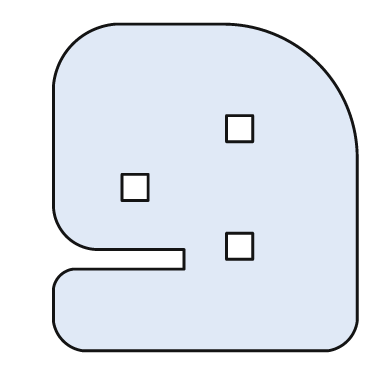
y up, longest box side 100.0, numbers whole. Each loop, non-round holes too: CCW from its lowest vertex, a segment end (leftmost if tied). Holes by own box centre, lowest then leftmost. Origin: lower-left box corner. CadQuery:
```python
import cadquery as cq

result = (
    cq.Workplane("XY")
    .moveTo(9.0, 0.0)
    .lineTo(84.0, 0.0)
    .threePointArc((90.0, 3.0), (93.0, 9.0))
    .lineTo(93.0, 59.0)
    .threePointArc((81.0, 88.0), (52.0, 100.0))
    .lineTo(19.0, 100.0)
    .threePointArc((6.0, 94.0), (0.0, 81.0))
    .lineTo(0.0, 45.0)
    .threePointArc((4.0, 35.0), (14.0, 31.0))
    .lineTo(40.0, 31.0)
    .lineTo(40.0, 25.0)
    .lineTo(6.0, 25.0)
    .threePointArc((2.0, 23.0), (0.0, 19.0))
    .lineTo(0.0, 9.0)
    .threePointArc((3.0, 3.0), (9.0, 0.0))
    .close()
    .moveTo(53.0, 28.0)
    .lineTo(61.0, 28.0)
    .lineTo(61.0, 36.0)
    .lineTo(53.0, 36.0)
    .close()
    .moveTo(21.0, 46.0)
    .lineTo(29.0, 46.0)
    .lineTo(29.0, 54.0)
    .lineTo(21.0, 54.0)
    .close()
    .moveTo(53.0, 64.0)
    .lineTo(61.0, 64.0)
    .lineTo(61.0, 72.0)
    .lineTo(53.0, 72.0)
    .close()
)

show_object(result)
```